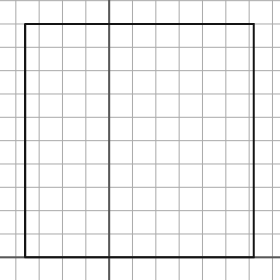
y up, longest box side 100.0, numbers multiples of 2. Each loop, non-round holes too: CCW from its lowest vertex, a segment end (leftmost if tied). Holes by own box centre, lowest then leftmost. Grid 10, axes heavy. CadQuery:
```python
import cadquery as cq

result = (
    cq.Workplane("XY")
    .moveTo(-36.0, 0.0)
    .lineTo(62.0, 0.0)
    .lineTo(62.0, 100.0)
    .lineTo(-36.0, 100.0)
    .close()
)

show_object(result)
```